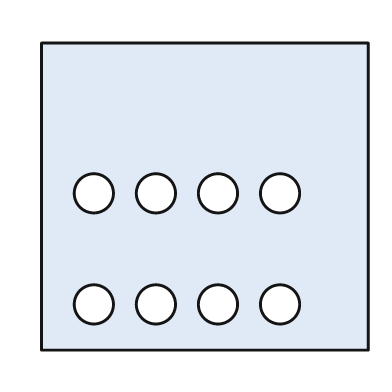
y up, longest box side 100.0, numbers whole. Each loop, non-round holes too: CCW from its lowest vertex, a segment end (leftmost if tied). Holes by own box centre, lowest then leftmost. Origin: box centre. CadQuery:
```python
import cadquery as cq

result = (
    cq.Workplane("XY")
    .moveTo(-50.0, -47.0)
    .lineTo(50.0, -47.0)
    .lineTo(50.0, 47.0)
    .lineTo(-50.0, 47.0)
    .close()
    .moveTo(-34.0, -33.0)
    .circle(6.0)
    .moveTo(-15.0, -33.0)
    .circle(6.0)
    .moveTo(4.0, -33.0)
    .circle(6.0)
    .moveTo(23.0, -33.0)
    .circle(6.0)
    .moveTo(-34.0, 1.0)
    .circle(6.0)
    .moveTo(-15.0, 1.0)
    .circle(6.0)
    .moveTo(4.0, 1.0)
    .circle(6.0)
    .moveTo(23.0, 1.0)
    .circle(6.0)
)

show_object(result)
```